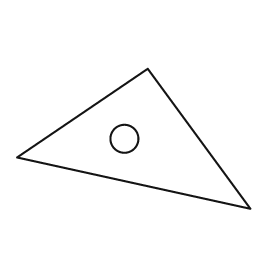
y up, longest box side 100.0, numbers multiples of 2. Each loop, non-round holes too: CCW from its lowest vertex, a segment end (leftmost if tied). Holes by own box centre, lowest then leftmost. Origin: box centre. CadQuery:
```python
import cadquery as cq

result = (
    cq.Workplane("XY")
    .moveTo(50.0, -30.0)
    .lineTo(6.0, 30.0)
    .lineTo(-50.0, -8.0)
    .close()
    .moveTo(-4.0, 0.0)
    .circle(6.0)
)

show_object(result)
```